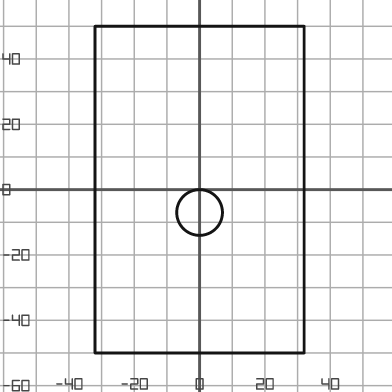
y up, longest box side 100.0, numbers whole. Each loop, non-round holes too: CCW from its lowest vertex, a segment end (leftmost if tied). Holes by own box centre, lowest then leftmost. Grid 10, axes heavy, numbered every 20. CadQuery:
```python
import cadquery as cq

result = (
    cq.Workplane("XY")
    .moveTo(-32.0, -50.0)
    .lineTo(32.0, -50.0)
    .lineTo(32.0, 50.0)
    .lineTo(-32.0, 50.0)
    .close()
    .moveTo(0.0, -7.0)
    .circle(7.0)
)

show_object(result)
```